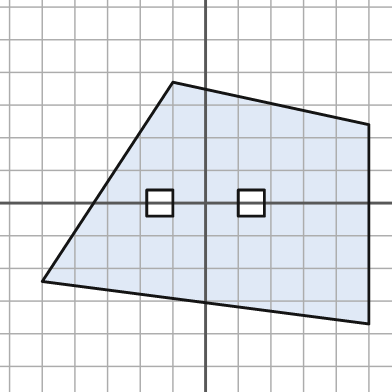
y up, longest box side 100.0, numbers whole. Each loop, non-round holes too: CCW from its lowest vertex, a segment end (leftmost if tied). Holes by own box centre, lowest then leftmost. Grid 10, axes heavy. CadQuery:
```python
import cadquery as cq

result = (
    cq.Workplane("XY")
    .moveTo(50.0, -37.0)
    .lineTo(50.0, 24.0)
    .lineTo(-10.0, 37.0)
    .lineTo(-50.0, -24.0)
    .close()
    .moveTo(-18.0, -4.0)
    .lineTo(-10.0, -4.0)
    .lineTo(-10.0, 4.0)
    .lineTo(-18.0, 4.0)
    .close()
    .moveTo(10.0, -4.0)
    .lineTo(18.0, -4.0)
    .lineTo(18.0, 4.0)
    .lineTo(10.0, 4.0)
    .close()
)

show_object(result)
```